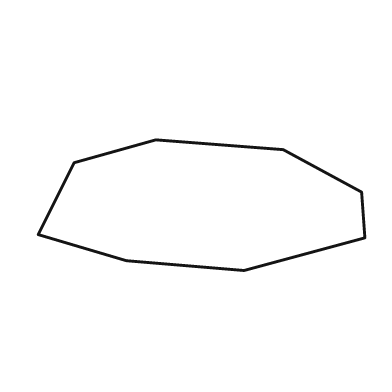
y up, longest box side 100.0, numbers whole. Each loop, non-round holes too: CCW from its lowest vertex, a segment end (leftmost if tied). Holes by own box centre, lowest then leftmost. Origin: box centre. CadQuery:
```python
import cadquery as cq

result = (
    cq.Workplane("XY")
    .moveTo(13.0, -20.0)
    .lineTo(50.0, -10.0)
    .lineTo(49.0, 4.0)
    .lineTo(25.0, 17.0)
    .lineTo(-14.0, 20.0)
    .lineTo(-39.0, 13.0)
    .lineTo(-50.0, -9.0)
    .lineTo(-23.0, -17.0)
    .close()
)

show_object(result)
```